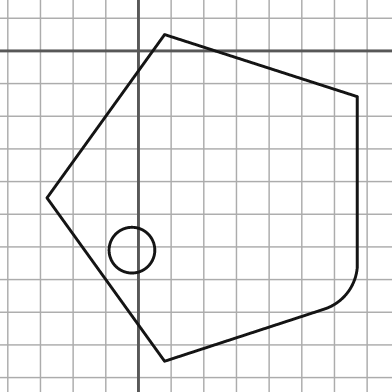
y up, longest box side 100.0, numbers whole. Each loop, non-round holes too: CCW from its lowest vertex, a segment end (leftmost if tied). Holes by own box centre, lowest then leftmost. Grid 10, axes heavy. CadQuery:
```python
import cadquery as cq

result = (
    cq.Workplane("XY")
    .moveTo(8.0, -95.0)
    .lineTo(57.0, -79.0)
    .threePointArc((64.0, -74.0), (67.0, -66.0))
    .lineTo(67.0, -14.0)
    .lineTo(8.0, 5.0)
    .lineTo(-28.0, -45.0)
    .close()
    .moveTo(-2.0, -61.0)
    .circle(7.0)
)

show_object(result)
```